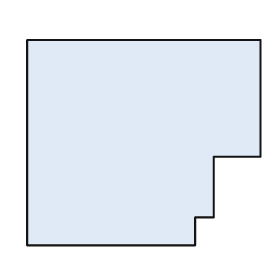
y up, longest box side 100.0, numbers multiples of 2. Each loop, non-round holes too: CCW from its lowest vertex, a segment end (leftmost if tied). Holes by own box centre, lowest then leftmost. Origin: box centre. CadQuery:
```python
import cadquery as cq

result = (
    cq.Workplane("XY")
    .moveTo(-50.0, -44.0)
    .lineTo(22.0, -44.0)
    .lineTo(22.0, -32.0)
    .lineTo(30.0, -32.0)
    .lineTo(30.0, -6.0)
    .lineTo(50.0, -6.0)
    .lineTo(50.0, 44.0)
    .lineTo(-50.0, 44.0)
    .close()
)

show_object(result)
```